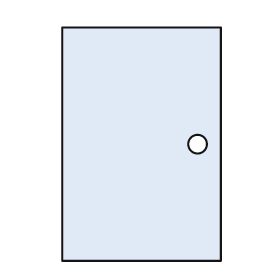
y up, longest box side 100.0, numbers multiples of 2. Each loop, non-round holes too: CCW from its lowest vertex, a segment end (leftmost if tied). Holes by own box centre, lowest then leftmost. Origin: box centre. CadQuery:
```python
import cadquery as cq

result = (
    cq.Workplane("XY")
    .moveTo(-34.0, -50.0)
    .lineTo(34.0, -50.0)
    .lineTo(34.0, 50.0)
    .lineTo(-34.0, 50.0)
    .close()
    .moveTo(24.0, 0.0)
    .circle(4.0)
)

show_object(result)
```